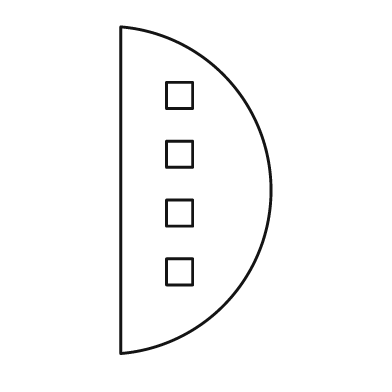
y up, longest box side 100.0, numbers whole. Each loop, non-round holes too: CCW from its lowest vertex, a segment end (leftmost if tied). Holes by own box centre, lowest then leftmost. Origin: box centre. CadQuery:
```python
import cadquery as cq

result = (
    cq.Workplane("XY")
    .moveTo(-23.0, -50.0)
    .threePointArc((23.0, 0.0), (-23.0, 50.0))
    .close()
    .moveTo(-9.0, -29.0)
    .lineTo(-1.0, -29.0)
    .lineTo(-1.0, -21.0)
    .lineTo(-9.0, -21.0)
    .close()
    .moveTo(-9.0, -11.0)
    .lineTo(-1.0, -11.0)
    .lineTo(-1.0, -3.0)
    .lineTo(-9.0, -3.0)
    .close()
    .moveTo(-9.0, 7.0)
    .lineTo(-1.0, 7.0)
    .lineTo(-1.0, 15.0)
    .lineTo(-9.0, 15.0)
    .close()
    .moveTo(-9.0, 25.0)
    .lineTo(-1.0, 25.0)
    .lineTo(-1.0, 33.0)
    .lineTo(-9.0, 33.0)
    .close()
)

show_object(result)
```